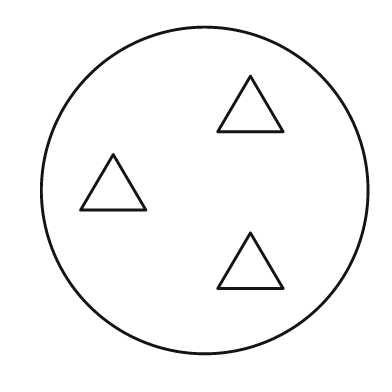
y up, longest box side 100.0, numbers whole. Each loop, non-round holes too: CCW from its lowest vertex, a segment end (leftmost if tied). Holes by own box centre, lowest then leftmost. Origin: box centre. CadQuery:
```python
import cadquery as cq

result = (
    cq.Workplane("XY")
    .moveTo(0.0, 0.0)
    .circle(50.0)
    .moveTo(4.0, -30.0)
    .lineTo(24.0, -30.0)
    .lineTo(14.0, -13.0)
    .close()
    .moveTo(-38.0, -6.0)
    .lineTo(-18.0, -6.0)
    .lineTo(-28.0, 11.0)
    .close()
    .moveTo(4.0, 18.0)
    .lineTo(24.0, 18.0)
    .lineTo(14.0, 35.0)
    .close()
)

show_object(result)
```